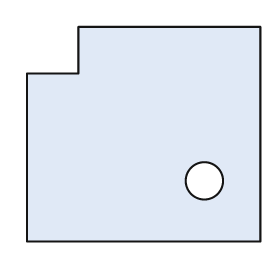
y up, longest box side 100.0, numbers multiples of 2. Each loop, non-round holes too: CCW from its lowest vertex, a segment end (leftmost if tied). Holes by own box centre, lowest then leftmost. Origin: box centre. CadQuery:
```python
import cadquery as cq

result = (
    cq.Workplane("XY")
    .moveTo(-50.0, -46.0)
    .lineTo(50.0, -46.0)
    .lineTo(50.0, 46.0)
    .lineTo(-28.0, 46.0)
    .lineTo(-28.0, 26.0)
    .lineTo(-50.0, 26.0)
    .close()
    .moveTo(26.0, -20.0)
    .circle(8.0)
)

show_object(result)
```